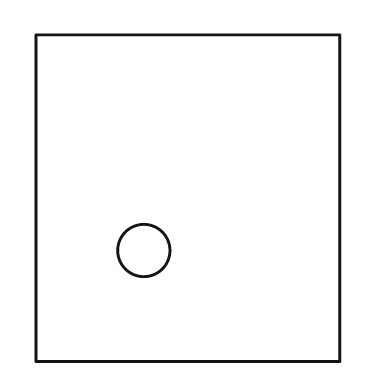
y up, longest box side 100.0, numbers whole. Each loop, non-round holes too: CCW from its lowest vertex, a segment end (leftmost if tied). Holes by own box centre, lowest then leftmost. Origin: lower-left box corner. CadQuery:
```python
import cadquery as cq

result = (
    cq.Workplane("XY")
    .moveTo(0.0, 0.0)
    .lineTo(93.0, 0.0)
    .lineTo(93.0, 100.0)
    .lineTo(0.0, 100.0)
    .close()
    .moveTo(33.0, 34.0)
    .circle(8.0)
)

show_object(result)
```